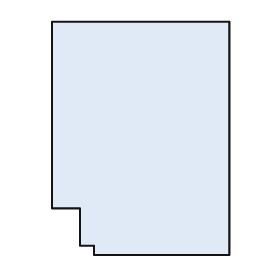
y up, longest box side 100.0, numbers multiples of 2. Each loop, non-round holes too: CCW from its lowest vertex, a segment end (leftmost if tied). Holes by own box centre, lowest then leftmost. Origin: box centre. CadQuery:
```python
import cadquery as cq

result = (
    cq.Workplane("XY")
    .moveTo(-20.0, -50.0)
    .lineTo(38.0, -50.0)
    .lineTo(38.0, 50.0)
    .lineTo(-38.0, 50.0)
    .lineTo(-38.0, -30.0)
    .lineTo(-26.0, -30.0)
    .lineTo(-26.0, -46.0)
    .lineTo(-20.0, -46.0)
    .close()
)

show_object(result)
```